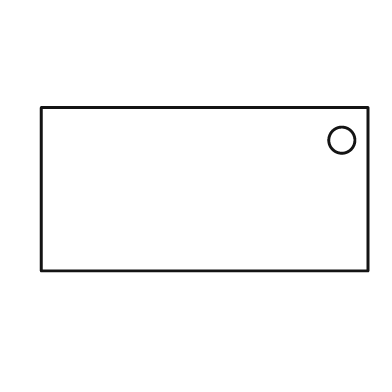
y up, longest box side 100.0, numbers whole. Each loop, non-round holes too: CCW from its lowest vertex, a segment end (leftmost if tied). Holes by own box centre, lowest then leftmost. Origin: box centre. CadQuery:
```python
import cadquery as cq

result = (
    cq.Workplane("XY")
    .moveTo(-50.0, -25.0)
    .lineTo(50.0, -25.0)
    .lineTo(50.0, 25.0)
    .lineTo(-50.0, 25.0)
    .close()
    .moveTo(42.0, 15.0)
    .circle(4.0)
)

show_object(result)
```